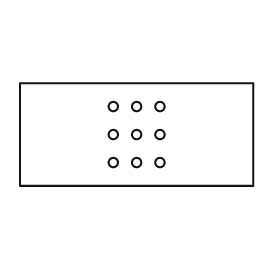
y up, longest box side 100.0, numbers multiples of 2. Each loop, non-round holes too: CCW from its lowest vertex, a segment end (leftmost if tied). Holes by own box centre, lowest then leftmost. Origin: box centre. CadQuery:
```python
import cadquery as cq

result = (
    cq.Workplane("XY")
    .moveTo(-50.0, -22.0)
    .lineTo(50.0, -22.0)
    .lineTo(50.0, 22.0)
    .lineTo(-50.0, 22.0)
    .close()
    .moveTo(-10.0, -12.0)
    .circle(2.0)
    .moveTo(0.0, -12.0)
    .circle(2.0)
    .moveTo(10.0, -12.0)
    .circle(2.0)
    .moveTo(-10.0, 0.0)
    .circle(2.0)
    .moveTo(0.0, 0.0)
    .circle(2.0)
    .moveTo(10.0, 0.0)
    .circle(2.0)
    .moveTo(-10.0, 12.0)
    .circle(2.0)
    .moveTo(0.0, 12.0)
    .circle(2.0)
    .moveTo(10.0, 12.0)
    .circle(2.0)
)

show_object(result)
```